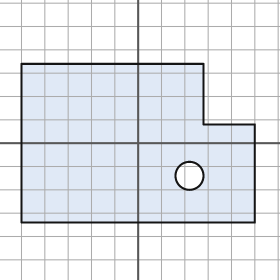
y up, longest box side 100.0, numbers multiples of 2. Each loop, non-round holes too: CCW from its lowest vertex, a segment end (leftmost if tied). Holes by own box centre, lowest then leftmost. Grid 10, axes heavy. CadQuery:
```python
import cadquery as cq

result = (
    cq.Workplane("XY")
    .moveTo(-50.0, -34.0)
    .lineTo(50.0, -34.0)
    .lineTo(50.0, 8.0)
    .lineTo(28.0, 8.0)
    .lineTo(28.0, 34.0)
    .lineTo(-50.0, 34.0)
    .close()
    .moveTo(22.0, -14.0)
    .circle(6.0)
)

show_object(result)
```